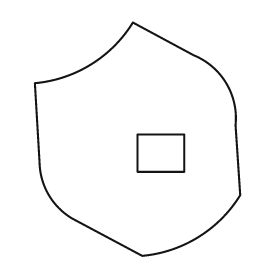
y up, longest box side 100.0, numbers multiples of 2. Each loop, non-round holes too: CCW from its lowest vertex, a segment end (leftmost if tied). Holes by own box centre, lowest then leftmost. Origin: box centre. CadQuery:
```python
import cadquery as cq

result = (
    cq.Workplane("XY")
    .moveTo(2.0, -50.0)
    .threePointArc((26.0, -42.0), (44.0, -24.0))
    .lineTo(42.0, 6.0)
    .threePointArc((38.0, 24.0), (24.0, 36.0))
    .lineTo(-2.0, 50.0)
    .threePointArc((-20.0, 32.0), (-44.0, 24.0))
    .lineTo(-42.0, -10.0)
    .threePointArc((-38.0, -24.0), (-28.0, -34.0))
    .close()
    .moveTo(0.0, -14.0)
    .lineTo(20.0, -14.0)
    .lineTo(20.0, 2.0)
    .lineTo(0.0, 2.0)
    .close()
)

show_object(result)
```